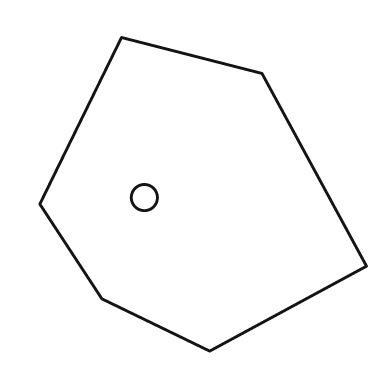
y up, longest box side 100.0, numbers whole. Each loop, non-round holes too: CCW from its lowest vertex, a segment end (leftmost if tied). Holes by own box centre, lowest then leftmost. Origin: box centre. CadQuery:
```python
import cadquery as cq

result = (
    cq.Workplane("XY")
    .moveTo(2.0, -48.0)
    .lineTo(50.0, -22.0)
    .lineTo(18.0, 37.0)
    .lineTo(-25.0, 48.0)
    .lineTo(-50.0, -3.0)
    .lineTo(-31.0, -32.0)
    .close()
    .moveTo(-18.0, -1.0)
    .circle(4.0)
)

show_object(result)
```